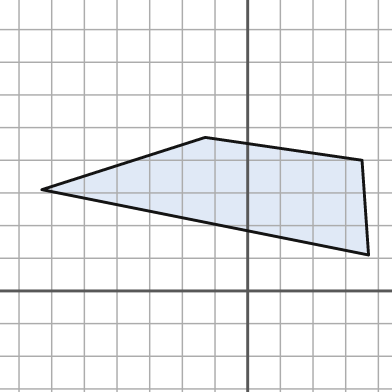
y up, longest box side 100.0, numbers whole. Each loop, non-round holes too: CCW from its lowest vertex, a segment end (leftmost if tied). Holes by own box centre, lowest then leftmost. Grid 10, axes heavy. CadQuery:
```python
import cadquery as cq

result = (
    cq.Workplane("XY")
    .moveTo(37.0, 11.0)
    .lineTo(35.0, 40.0)
    .lineTo(-13.0, 47.0)
    .lineTo(-63.0, 31.0)
    .close()
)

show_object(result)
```